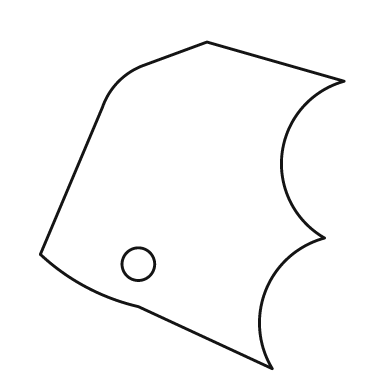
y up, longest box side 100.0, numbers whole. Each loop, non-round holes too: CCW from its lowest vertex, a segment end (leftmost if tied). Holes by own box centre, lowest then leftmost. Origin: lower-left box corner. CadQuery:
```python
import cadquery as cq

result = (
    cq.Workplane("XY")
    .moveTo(71.0, 0.0)
    .threePointArc((69.0, 24.0), (87.0, 40.0))
    .threePointArc((74.0, 66.0), (93.0, 88.0))
    .lineTo(51.0, 100.0)
    .lineTo(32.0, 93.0)
    .threePointArc((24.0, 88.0), (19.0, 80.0))
    .lineTo(0.0, 35.0)
    .threePointArc((14.0, 25.0), (30.0, 19.0))
    .close()
    .moveTo(30.0, 32.0)
    .circle(5.0)
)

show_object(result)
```